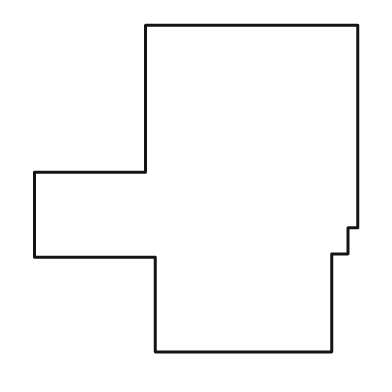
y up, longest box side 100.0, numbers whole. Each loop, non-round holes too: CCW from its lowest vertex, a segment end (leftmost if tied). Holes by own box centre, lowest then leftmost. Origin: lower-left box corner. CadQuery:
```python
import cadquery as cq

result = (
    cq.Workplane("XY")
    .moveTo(37.0, 0.0)
    .lineTo(91.0, 0.0)
    .lineTo(91.0, 30.0)
    .lineTo(96.0, 30.0)
    .lineTo(96.0, 38.0)
    .lineTo(99.0, 38.0)
    .lineTo(99.0, 100.0)
    .lineTo(34.0, 100.0)
    .lineTo(34.0, 55.0)
    .lineTo(0.0, 55.0)
    .lineTo(0.0, 29.0)
    .lineTo(37.0, 29.0)
    .close()
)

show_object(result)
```